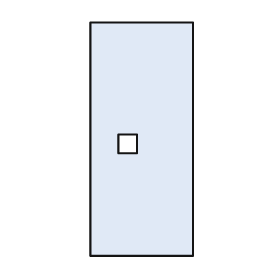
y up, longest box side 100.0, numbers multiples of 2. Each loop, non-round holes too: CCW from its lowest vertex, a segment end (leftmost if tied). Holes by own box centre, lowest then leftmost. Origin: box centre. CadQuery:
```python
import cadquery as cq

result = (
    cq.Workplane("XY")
    .moveTo(-22.0, -50.0)
    .lineTo(22.0, -50.0)
    .lineTo(22.0, 50.0)
    .lineTo(-22.0, 50.0)
    .close()
    .moveTo(-10.0, -6.0)
    .lineTo(-2.0, -6.0)
    .lineTo(-2.0, 2.0)
    .lineTo(-10.0, 2.0)
    .close()
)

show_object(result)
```